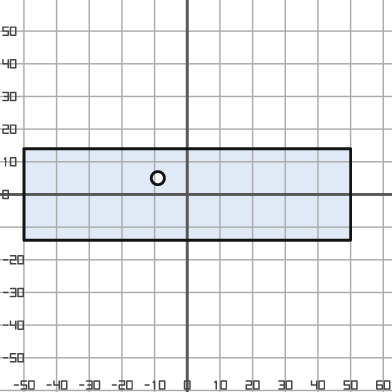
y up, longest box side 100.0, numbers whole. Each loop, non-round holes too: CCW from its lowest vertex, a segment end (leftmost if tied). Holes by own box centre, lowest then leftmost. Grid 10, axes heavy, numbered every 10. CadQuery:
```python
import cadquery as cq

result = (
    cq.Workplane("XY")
    .moveTo(-50.0, -14.0)
    .lineTo(50.0, -14.0)
    .lineTo(50.0, 14.0)
    .lineTo(-50.0, 14.0)
    .close()
    .moveTo(-9.0, 5.0)
    .circle(2.0)
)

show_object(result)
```